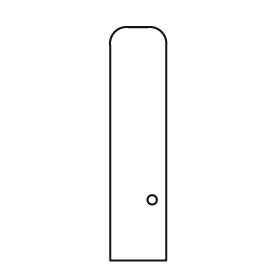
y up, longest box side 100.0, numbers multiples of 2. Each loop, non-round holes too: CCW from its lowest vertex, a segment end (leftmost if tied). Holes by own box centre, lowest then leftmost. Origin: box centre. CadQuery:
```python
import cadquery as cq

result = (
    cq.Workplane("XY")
    .moveTo(-12.0, -50.0)
    .lineTo(12.0, -50.0)
    .lineTo(12.0, 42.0)
    .threePointArc((10.0, 48.0), (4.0, 50.0))
    .lineTo(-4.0, 50.0)
    .threePointArc((-10.0, 48.0), (-12.0, 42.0))
    .close()
    .moveTo(6.0, -24.0)
    .circle(2.0)
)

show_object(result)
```